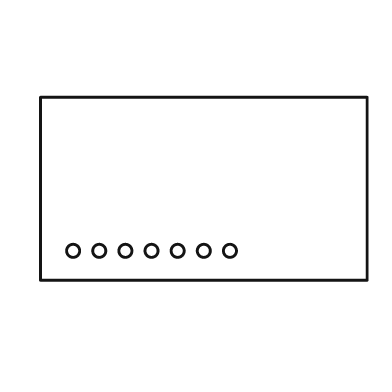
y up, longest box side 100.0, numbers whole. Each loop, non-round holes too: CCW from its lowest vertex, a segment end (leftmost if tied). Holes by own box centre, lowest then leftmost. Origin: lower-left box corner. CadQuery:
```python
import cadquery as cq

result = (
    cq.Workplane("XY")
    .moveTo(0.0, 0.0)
    .lineTo(100.0, 0.0)
    .lineTo(100.0, 56.0)
    .lineTo(0.0, 56.0)
    .close()
    .moveTo(10.0, 9.0)
    .circle(2.0)
    .moveTo(18.0, 9.0)
    .circle(2.0)
    .moveTo(26.0, 9.0)
    .circle(2.0)
    .moveTo(34.0, 9.0)
    .circle(2.0)
    .moveTo(42.0, 9.0)
    .circle(2.0)
    .moveTo(50.0, 9.0)
    .circle(2.0)
    .moveTo(58.0, 9.0)
    .circle(2.0)
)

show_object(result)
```